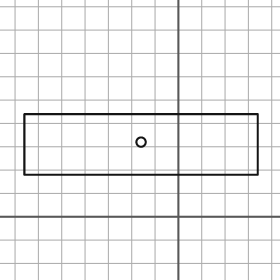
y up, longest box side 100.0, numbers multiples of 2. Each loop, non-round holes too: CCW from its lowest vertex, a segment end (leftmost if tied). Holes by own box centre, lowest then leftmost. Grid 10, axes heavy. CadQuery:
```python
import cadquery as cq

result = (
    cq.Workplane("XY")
    .moveTo(-66.0, 18.0)
    .lineTo(34.0, 18.0)
    .lineTo(34.0, 44.0)
    .lineTo(-66.0, 44.0)
    .close()
    .moveTo(-16.0, 32.0)
    .circle(2.0)
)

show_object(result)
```